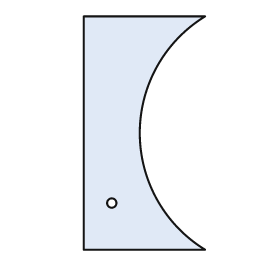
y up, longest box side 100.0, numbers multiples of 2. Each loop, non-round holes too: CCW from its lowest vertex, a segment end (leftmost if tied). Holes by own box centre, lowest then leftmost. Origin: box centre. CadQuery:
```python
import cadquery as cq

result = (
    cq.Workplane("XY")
    .moveTo(-26.0, -50.0)
    .lineTo(26.0, -50.0)
    .threePointArc((-2.0, 0.0), (26.0, 50.0))
    .lineTo(-26.0, 50.0)
    .close()
    .moveTo(-14.0, -30.0)
    .circle(2.0)
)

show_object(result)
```